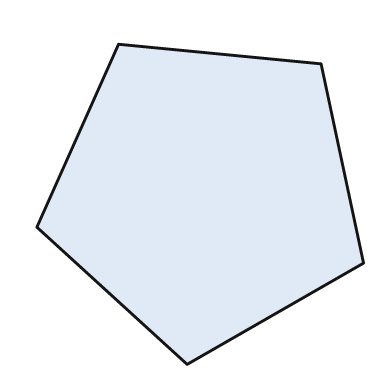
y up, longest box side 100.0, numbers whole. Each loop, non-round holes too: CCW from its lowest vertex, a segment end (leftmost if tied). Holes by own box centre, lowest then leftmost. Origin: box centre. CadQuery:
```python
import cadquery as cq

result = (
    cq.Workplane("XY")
    .moveTo(-4.0, -49.0)
    .lineTo(50.0, -18.0)
    .lineTo(37.0, 43.0)
    .lineTo(-25.0, 49.0)
    .lineTo(-50.0, -7.0)
    .close()
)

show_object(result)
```